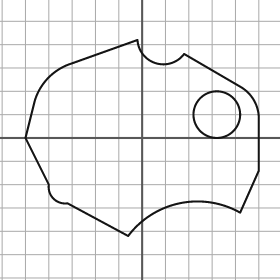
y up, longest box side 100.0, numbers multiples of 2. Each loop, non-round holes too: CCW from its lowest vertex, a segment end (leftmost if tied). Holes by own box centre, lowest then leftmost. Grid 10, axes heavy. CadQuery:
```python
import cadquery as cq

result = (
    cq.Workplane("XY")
    .moveTo(-6.0, -42.0)
    .threePointArc((16.0, -28.0), (42.0, -32.0))
    .lineTo(50.0, -14.0)
    .lineTo(50.0, 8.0)
    .threePointArc((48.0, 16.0), (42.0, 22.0))
    .lineTo(18.0, 36.0)
    .threePointArc((6.0, 32.0), (-2.0, 42.0))
    .lineTo(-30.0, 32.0)
    .threePointArc((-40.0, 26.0), (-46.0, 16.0))
    .lineTo(-50.0, 0.0)
    .lineTo(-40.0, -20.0)
    .threePointArc((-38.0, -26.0), (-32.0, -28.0))
    .close()
    .moveTo(32.0, 10.0)
    .circle(10.0)
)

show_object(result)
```